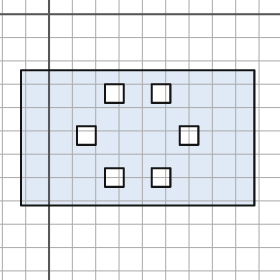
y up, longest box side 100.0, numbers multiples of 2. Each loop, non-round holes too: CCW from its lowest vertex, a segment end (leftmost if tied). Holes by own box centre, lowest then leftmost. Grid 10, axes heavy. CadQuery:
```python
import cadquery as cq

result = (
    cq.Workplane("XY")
    .moveTo(-12.0, -82.0)
    .lineTo(88.0, -82.0)
    .lineTo(88.0, -24.0)
    .lineTo(-12.0, -24.0)
    .close()
    .moveTo(24.0, -74.0)
    .lineTo(32.0, -74.0)
    .lineTo(32.0, -66.0)
    .lineTo(24.0, -66.0)
    .close()
    .moveTo(44.0, -74.0)
    .lineTo(52.0, -74.0)
    .lineTo(52.0, -66.0)
    .lineTo(44.0, -66.0)
    .close()
    .moveTo(12.0, -56.0)
    .lineTo(20.0, -56.0)
    .lineTo(20.0, -48.0)
    .lineTo(12.0, -48.0)
    .close()
    .moveTo(56.0, -56.0)
    .lineTo(64.0, -56.0)
    .lineTo(64.0, -48.0)
    .lineTo(56.0, -48.0)
    .close()
    .moveTo(24.0, -38.0)
    .lineTo(32.0, -38.0)
    .lineTo(32.0, -30.0)
    .lineTo(24.0, -30.0)
    .close()
    .moveTo(44.0, -38.0)
    .lineTo(52.0, -38.0)
    .lineTo(52.0, -30.0)
    .lineTo(44.0, -30.0)
    .close()
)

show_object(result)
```